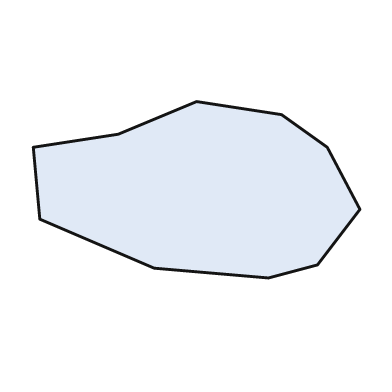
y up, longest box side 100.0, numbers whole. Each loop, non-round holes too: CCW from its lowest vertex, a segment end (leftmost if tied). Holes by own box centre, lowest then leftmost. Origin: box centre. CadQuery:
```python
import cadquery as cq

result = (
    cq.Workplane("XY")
    .moveTo(22.0, -27.0)
    .lineTo(37.0, -23.0)
    .lineTo(50.0, -6.0)
    .lineTo(40.0, 13.0)
    .lineTo(26.0, 23.0)
    .lineTo(0.0, 27.0)
    .lineTo(-24.0, 17.0)
    .lineTo(-50.0, 13.0)
    .lineTo(-48.0, -9.0)
    .lineTo(-13.0, -24.0)
    .close()
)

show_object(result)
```